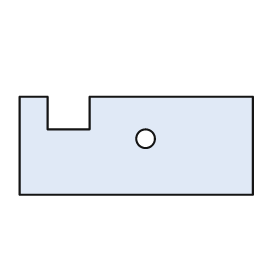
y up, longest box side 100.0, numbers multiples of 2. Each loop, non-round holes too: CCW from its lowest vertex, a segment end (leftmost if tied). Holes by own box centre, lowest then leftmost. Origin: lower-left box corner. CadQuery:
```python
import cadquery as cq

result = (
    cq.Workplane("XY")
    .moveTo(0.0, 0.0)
    .lineTo(100.0, 0.0)
    .lineTo(100.0, 42.0)
    .lineTo(30.0, 42.0)
    .lineTo(30.0, 28.0)
    .lineTo(12.0, 28.0)
    .lineTo(12.0, 42.0)
    .lineTo(0.0, 42.0)
    .close()
    .moveTo(54.0, 24.0)
    .circle(4.0)
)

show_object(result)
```